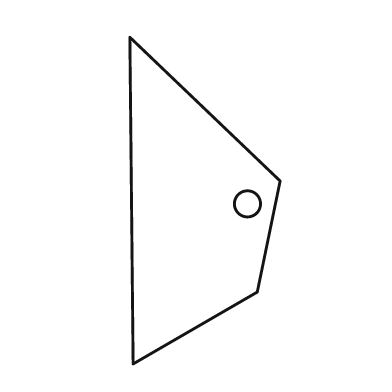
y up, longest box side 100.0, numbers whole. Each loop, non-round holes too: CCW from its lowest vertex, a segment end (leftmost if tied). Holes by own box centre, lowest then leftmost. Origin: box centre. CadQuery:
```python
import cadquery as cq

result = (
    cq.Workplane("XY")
    .moveTo(-22.0, -50.0)
    .lineTo(16.0, -28.0)
    .lineTo(23.0, 6.0)
    .lineTo(-23.0, 50.0)
    .close()
    .moveTo(13.0, -1.0)
    .circle(4.0)
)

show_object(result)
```